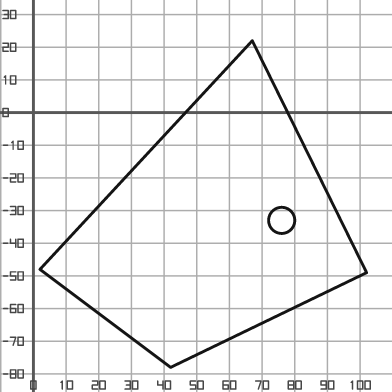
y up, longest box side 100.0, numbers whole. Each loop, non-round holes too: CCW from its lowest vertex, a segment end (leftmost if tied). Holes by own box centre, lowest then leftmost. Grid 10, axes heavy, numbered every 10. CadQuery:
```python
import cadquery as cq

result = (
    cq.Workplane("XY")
    .moveTo(42.0, -78.0)
    .lineTo(102.0, -49.0)
    .lineTo(67.0, 22.0)
    .lineTo(2.0, -48.0)
    .close()
    .moveTo(76.0, -33.0)
    .circle(4.0)
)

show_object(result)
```